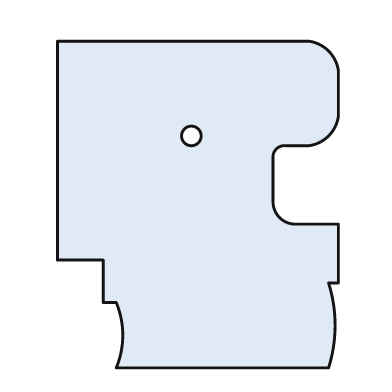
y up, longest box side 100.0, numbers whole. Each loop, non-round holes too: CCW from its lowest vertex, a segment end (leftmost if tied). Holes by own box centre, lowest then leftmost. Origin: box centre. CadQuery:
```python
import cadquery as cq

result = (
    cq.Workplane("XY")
    .moveTo(-25.0, -50.0)
    .lineTo(40.0, -50.0)
    .threePointArc((42.0, -37.0), (40.0, -24.0))
    .lineTo(43.0, -24.0)
    .lineTo(43.0, -6.0)
    .lineTo(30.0, -6.0)
    .threePointArc((25.0, -4.0), (23.0, 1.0))
    .lineTo(23.0, 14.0)
    .threePointArc((24.0, 17.0), (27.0, 18.0))
    .lineTo(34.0, 18.0)
    .threePointArc((40.0, 21.0), (43.0, 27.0))
    .lineTo(43.0, 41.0)
    .threePointArc((40.0, 47.0), (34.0, 50.0))
    .lineTo(-43.0, 50.0)
    .lineTo(-43.0, -17.0)
    .lineTo(-29.0, -17.0)
    .lineTo(-29.0, -30.0)
    .lineTo(-25.0, -30.0)
    .threePointArc((-23.0, -40.0), (-25.0, -50.0))
    .close()
    .moveTo(-2.0, 21.0)
    .circle(3.0)
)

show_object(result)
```